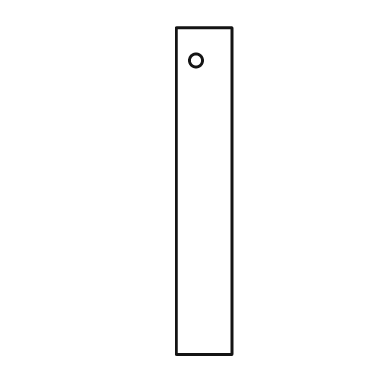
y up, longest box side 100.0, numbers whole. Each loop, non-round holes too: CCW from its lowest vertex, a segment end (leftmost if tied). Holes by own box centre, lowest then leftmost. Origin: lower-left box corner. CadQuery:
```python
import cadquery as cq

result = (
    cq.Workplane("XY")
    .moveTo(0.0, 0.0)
    .lineTo(17.0, 0.0)
    .lineTo(17.0, 100.0)
    .lineTo(0.0, 100.0)
    .close()
    .moveTo(6.0, 90.0)
    .circle(2.0)
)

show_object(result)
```